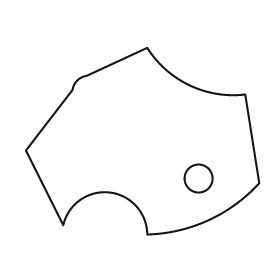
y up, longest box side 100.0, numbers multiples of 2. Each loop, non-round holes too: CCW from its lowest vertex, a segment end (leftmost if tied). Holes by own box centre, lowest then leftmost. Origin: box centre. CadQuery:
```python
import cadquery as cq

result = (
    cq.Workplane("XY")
    .moveTo(2.0, -40.0)
    .threePointArc((28.0, -34.0), (50.0, -18.0))
    .lineTo(44.0, 20.0)
    .threePointArc((20.0, 24.0), (2.0, 40.0))
    .lineTo(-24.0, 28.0)
    .threePointArc((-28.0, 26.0), (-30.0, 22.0))
    .lineTo(-50.0, -4.0)
    .lineTo(-34.0, -36.0)
    .threePointArc((-14.0, -22.0), (2.0, -40.0))
    .close()
    .moveTo(24.0, -16.0)
    .circle(6.0)
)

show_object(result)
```